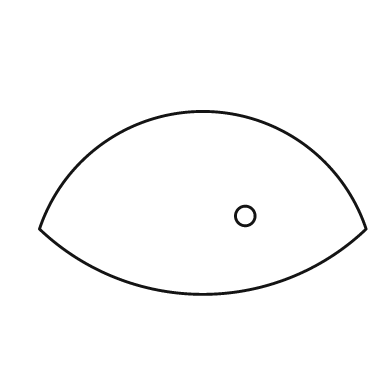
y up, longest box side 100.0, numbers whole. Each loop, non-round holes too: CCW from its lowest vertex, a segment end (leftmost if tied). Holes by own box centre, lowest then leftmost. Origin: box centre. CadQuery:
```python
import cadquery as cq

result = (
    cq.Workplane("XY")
    .moveTo(-50.0, -8.0)
    .threePointArc((0.0, -28.0), (50.0, -8.0))
    .threePointArc((0.0, 28.0), (-50.0, -8.0))
    .close()
    .moveTo(13.0, -4.0)
    .circle(3.0)
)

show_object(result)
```